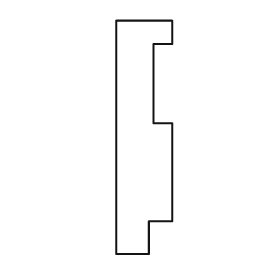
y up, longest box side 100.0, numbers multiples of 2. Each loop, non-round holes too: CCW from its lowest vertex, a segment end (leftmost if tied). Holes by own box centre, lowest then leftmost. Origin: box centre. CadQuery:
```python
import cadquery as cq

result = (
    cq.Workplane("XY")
    .moveTo(-12.0, -50.0)
    .lineTo(2.0, -50.0)
    .lineTo(2.0, -36.0)
    .lineTo(12.0, -36.0)
    .lineTo(12.0, 6.0)
    .lineTo(4.0, 6.0)
    .lineTo(4.0, 40.0)
    .lineTo(12.0, 40.0)
    .lineTo(12.0, 50.0)
    .lineTo(-12.0, 50.0)
    .close()
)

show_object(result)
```